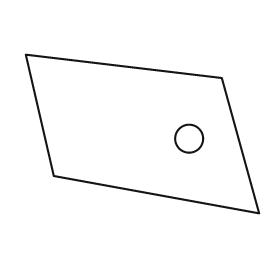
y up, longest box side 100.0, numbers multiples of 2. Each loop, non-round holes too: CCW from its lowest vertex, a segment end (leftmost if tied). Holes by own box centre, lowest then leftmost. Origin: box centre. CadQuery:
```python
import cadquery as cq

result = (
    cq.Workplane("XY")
    .moveTo(50.0, -34.0)
    .lineTo(34.0, 24.0)
    .lineTo(-50.0, 34.0)
    .lineTo(-38.0, -18.0)
    .close()
    .moveTo(20.0, -2.0)
    .circle(6.0)
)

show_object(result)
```